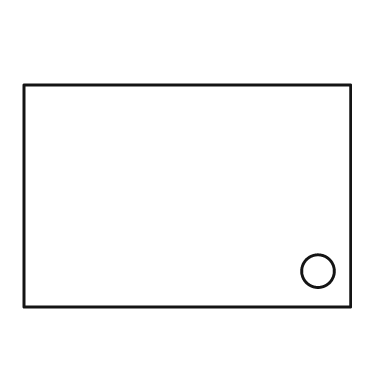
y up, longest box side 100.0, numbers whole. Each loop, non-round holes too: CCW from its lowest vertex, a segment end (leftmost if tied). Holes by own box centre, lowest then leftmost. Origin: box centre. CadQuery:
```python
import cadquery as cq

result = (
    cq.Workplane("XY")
    .moveTo(-50.0, -34.0)
    .lineTo(50.0, -34.0)
    .lineTo(50.0, 34.0)
    .lineTo(-50.0, 34.0)
    .close()
    .moveTo(40.0, -23.0)
    .circle(5.0)
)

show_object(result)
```